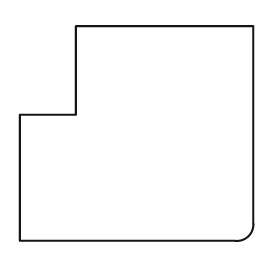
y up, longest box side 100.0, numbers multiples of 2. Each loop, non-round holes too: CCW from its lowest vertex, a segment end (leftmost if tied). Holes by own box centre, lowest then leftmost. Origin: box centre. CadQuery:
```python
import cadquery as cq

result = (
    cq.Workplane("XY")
    .moveTo(-50.0, -46.0)
    .lineTo(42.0, -46.0)
    .threePointArc((48.0, -44.0), (50.0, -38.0))
    .lineTo(50.0, 46.0)
    .lineTo(-26.0, 46.0)
    .lineTo(-26.0, 8.0)
    .lineTo(-50.0, 8.0)
    .close()
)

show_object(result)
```